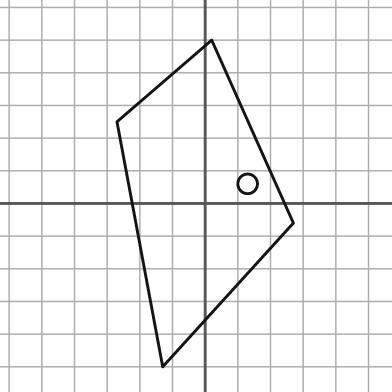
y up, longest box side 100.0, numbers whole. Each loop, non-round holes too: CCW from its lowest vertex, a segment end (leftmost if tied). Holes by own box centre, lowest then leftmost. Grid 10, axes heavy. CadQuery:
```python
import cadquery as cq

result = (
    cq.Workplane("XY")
    .moveTo(-13.0, -50.0)
    .lineTo(27.0, -6.0)
    .lineTo(2.0, 50.0)
    .lineTo(-27.0, 25.0)
    .close()
    .moveTo(13.0, 6.0)
    .circle(3.0)
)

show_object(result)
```